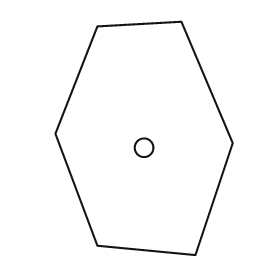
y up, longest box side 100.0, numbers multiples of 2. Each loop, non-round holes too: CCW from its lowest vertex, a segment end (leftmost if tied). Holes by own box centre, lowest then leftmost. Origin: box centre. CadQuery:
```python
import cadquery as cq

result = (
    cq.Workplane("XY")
    .moveTo(22.0, -50.0)
    .lineTo(38.0, -2.0)
    .lineTo(16.0, 50.0)
    .lineTo(-20.0, 48.0)
    .lineTo(-38.0, 2.0)
    .lineTo(-20.0, -46.0)
    .close()
    .moveTo(0.0, -4.0)
    .circle(4.0)
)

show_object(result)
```